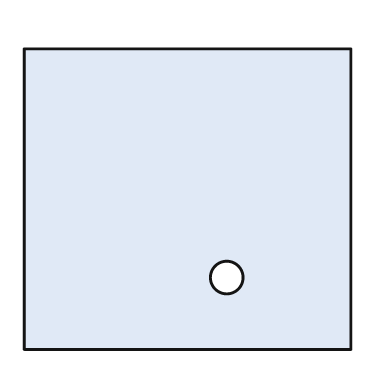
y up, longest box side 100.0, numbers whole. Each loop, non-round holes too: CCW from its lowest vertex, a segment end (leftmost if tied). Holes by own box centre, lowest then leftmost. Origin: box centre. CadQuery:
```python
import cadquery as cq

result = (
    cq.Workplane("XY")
    .moveTo(-50.0, -46.0)
    .lineTo(50.0, -46.0)
    .lineTo(50.0, 46.0)
    .lineTo(-50.0, 46.0)
    .close()
    .moveTo(12.0, -24.0)
    .circle(5.0)
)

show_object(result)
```